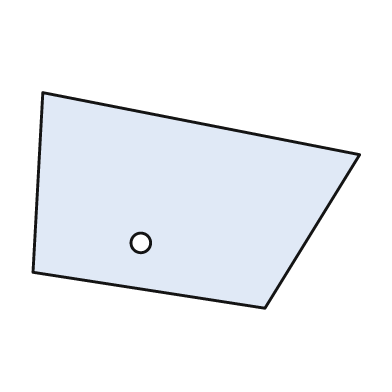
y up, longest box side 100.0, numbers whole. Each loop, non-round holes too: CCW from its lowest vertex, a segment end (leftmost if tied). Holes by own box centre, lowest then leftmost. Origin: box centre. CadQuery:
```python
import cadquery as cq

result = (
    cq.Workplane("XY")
    .moveTo(21.0, -33.0)
    .lineTo(50.0, 14.0)
    .lineTo(-47.0, 33.0)
    .lineTo(-50.0, -22.0)
    .close()
    .moveTo(-17.0, -13.0)
    .circle(3.0)
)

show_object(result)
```